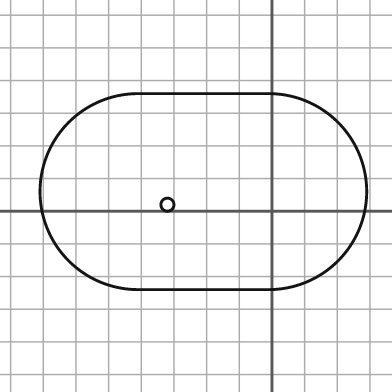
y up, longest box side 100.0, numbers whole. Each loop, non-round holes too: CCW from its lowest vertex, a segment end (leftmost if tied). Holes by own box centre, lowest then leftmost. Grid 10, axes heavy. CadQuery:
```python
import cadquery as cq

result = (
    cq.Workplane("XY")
    .moveTo(-41.0, -24.0)
    .lineTo(-1.0, -24.0)
    .threePointArc((29.0, 6.0), (-1.0, 36.0))
    .lineTo(-41.0, 36.0)
    .threePointArc((-71.0, 6.0), (-41.0, -24.0))
    .close()
    .moveTo(-32.0, 2.0)
    .circle(2.0)
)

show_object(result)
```